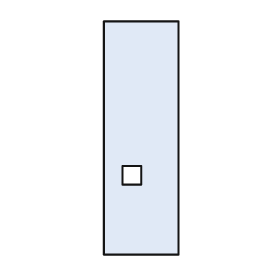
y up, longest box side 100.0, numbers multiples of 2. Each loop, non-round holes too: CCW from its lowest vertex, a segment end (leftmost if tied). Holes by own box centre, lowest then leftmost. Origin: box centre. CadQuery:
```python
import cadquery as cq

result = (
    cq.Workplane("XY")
    .moveTo(-16.0, -50.0)
    .lineTo(16.0, -50.0)
    .lineTo(16.0, 50.0)
    .lineTo(-16.0, 50.0)
    .close()
    .moveTo(-8.0, -20.0)
    .lineTo(0.0, -20.0)
    .lineTo(0.0, -12.0)
    .lineTo(-8.0, -12.0)
    .close()
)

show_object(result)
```